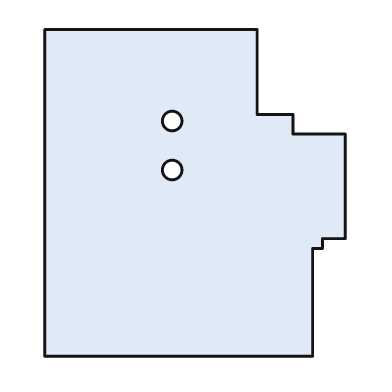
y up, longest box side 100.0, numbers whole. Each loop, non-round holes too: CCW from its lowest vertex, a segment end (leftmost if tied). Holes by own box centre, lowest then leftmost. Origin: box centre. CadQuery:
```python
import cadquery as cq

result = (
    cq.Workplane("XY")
    .moveTo(-46.0, -50.0)
    .lineTo(36.0, -50.0)
    .lineTo(36.0, -17.0)
    .lineTo(39.0, -17.0)
    .lineTo(39.0, -14.0)
    .lineTo(46.0, -14.0)
    .lineTo(46.0, 18.0)
    .lineTo(30.0, 18.0)
    .lineTo(30.0, 24.0)
    .lineTo(19.0, 24.0)
    .lineTo(19.0, 50.0)
    .lineTo(-46.0, 50.0)
    .close()
    .moveTo(-7.0, 7.0)
    .circle(3.0)
    .moveTo(-7.0, 22.0)
    .circle(3.0)
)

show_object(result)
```